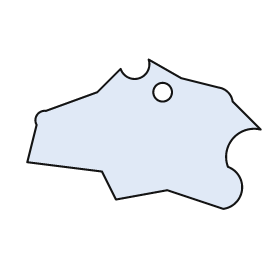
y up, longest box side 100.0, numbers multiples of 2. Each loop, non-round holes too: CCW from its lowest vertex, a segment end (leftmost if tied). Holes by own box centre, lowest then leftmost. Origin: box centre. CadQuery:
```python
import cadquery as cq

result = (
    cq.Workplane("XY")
    .moveTo(34.0, -32.0)
    .threePointArc((42.0, -24.0), (36.0, -14.0))
    .threePointArc((38.0, -2.0), (50.0, 2.0))
    .lineTo(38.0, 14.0)
    .threePointArc((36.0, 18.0), (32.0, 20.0))
    .lineTo(16.0, 24.0)
    .lineTo(2.0, 32.0)
    .threePointArc((-2.0, 24.0), (-10.0, 28.0))
    .lineTo(-20.0, 18.0)
    .lineTo(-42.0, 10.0)
    .threePointArc((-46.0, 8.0), (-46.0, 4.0))
    .lineTo(-50.0, -12.0)
    .lineTo(-18.0, -16.0)
    .lineTo(-12.0, -28.0)
    .lineTo(10.0, -24.0)
    .close()
    .moveTo(8.0, 18.0)
    .circle(4.0)
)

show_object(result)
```